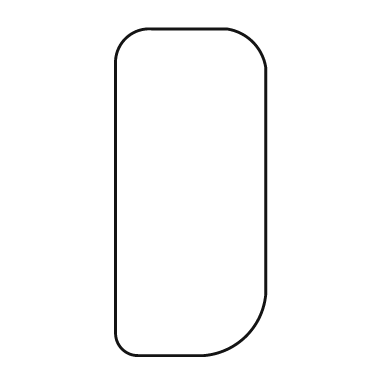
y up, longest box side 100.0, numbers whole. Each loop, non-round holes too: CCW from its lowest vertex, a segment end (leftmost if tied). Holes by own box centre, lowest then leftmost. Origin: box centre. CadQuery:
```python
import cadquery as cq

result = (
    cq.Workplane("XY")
    .moveTo(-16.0, -50.0)
    .lineTo(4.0, -50.0)
    .threePointArc((17.0, -44.0), (23.0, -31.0))
    .lineTo(23.0, 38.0)
    .threePointArc((19.0, 46.0), (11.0, 50.0))
    .lineTo(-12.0, 50.0)
    .threePointArc((-20.0, 47.0), (-23.0, 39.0))
    .lineTo(-23.0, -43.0)
    .threePointArc((-21.0, -48.0), (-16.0, -50.0))
    .close()
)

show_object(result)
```